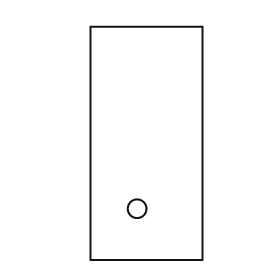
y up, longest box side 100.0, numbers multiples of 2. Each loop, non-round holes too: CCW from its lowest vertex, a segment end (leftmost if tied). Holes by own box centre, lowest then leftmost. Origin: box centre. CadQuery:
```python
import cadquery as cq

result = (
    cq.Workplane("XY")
    .moveTo(-24.0, -50.0)
    .lineTo(24.0, -50.0)
    .lineTo(24.0, 50.0)
    .lineTo(-24.0, 50.0)
    .close()
    .moveTo(-4.0, -28.0)
    .circle(4.0)
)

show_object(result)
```